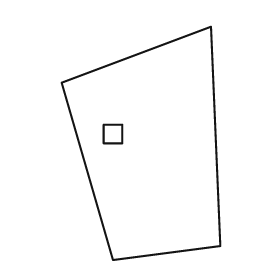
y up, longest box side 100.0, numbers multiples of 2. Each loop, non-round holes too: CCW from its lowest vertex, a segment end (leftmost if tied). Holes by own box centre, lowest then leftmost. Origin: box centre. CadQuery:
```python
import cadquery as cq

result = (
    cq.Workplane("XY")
    .moveTo(-12.0, -50.0)
    .lineTo(34.0, -44.0)
    .lineTo(30.0, 50.0)
    .lineTo(-34.0, 26.0)
    .close()
    .moveTo(-16.0, 0.0)
    .lineTo(-8.0, 0.0)
    .lineTo(-8.0, 8.0)
    .lineTo(-16.0, 8.0)
    .close()
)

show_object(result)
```